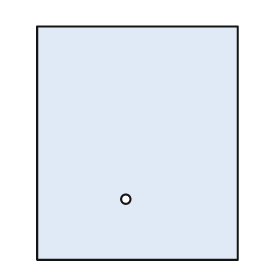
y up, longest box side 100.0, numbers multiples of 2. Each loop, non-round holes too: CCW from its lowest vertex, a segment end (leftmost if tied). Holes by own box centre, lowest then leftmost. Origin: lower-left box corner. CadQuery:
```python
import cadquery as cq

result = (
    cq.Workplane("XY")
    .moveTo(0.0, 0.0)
    .lineTo(86.0, 0.0)
    .lineTo(86.0, 100.0)
    .lineTo(0.0, 100.0)
    .close()
    .moveTo(38.0, 26.0)
    .circle(2.0)
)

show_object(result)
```